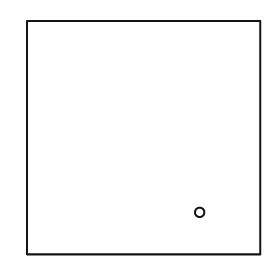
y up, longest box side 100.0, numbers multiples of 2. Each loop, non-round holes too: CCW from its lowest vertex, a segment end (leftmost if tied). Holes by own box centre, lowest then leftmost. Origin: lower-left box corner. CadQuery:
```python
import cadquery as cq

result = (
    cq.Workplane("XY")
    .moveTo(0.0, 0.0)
    .lineTo(100.0, 0.0)
    .lineTo(100.0, 100.0)
    .lineTo(0.0, 100.0)
    .close()
    .moveTo(74.0, 18.0)
    .circle(2.0)
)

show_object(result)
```